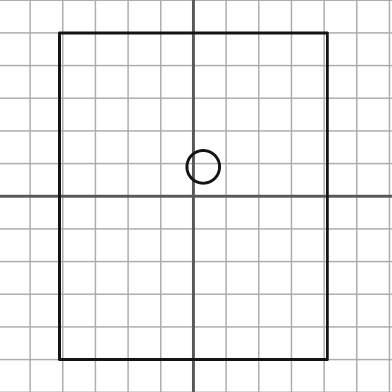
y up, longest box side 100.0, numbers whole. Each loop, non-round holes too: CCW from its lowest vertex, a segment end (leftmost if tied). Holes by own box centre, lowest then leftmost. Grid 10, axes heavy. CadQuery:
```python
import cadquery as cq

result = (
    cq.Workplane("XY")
    .moveTo(-41.0, -50.0)
    .lineTo(41.0, -50.0)
    .lineTo(41.0, 50.0)
    .lineTo(-41.0, 50.0)
    .close()
    .moveTo(3.0, 9.0)
    .circle(5.0)
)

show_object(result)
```